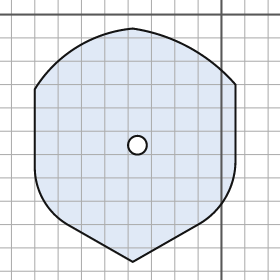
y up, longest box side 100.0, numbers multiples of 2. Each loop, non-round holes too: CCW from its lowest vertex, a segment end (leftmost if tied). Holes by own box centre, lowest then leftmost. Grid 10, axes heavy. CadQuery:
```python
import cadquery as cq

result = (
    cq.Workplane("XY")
    .moveTo(-38.0, -106.0)
    .lineTo(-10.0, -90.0)
    .threePointArc((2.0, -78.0), (6.0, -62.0))
    .lineTo(6.0, -30.0)
    .threePointArc((-14.0, -14.0), (-38.0, -6.0))
    .threePointArc((-62.0, -14.0), (-80.0, -32.0))
    .lineTo(-80.0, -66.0)
    .threePointArc((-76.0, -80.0), (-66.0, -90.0))
    .close()
    .moveTo(-36.0, -56.0)
    .circle(4.0)
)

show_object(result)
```